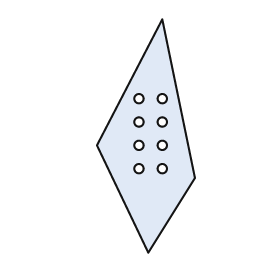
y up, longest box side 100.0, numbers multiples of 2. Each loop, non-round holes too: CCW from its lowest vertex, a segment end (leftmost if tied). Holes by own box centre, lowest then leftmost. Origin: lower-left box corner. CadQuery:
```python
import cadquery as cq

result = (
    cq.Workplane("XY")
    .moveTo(22.0, 0.0)
    .lineTo(42.0, 32.0)
    .lineTo(28.0, 100.0)
    .lineTo(0.0, 46.0)
    .close()
    .moveTo(18.0, 36.0)
    .circle(2.0)
    .moveTo(28.0, 36.0)
    .circle(2.0)
    .moveTo(18.0, 46.0)
    .circle(2.0)
    .moveTo(28.0, 46.0)
    .circle(2.0)
    .moveTo(18.0, 56.0)
    .circle(2.0)
    .moveTo(28.0, 56.0)
    .circle(2.0)
    .moveTo(18.0, 66.0)
    .circle(2.0)
    .moveTo(28.0, 66.0)
    .circle(2.0)
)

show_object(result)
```